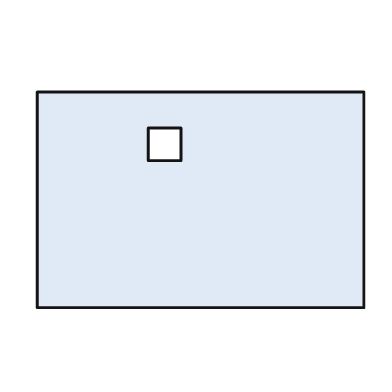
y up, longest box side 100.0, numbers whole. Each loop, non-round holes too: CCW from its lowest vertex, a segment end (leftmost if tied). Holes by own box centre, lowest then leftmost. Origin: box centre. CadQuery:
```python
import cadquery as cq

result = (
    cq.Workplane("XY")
    .moveTo(-50.0, -33.0)
    .lineTo(50.0, -33.0)
    .lineTo(50.0, 33.0)
    .lineTo(-50.0, 33.0)
    .close()
    .moveTo(-16.0, 12.0)
    .lineTo(-6.0, 12.0)
    .lineTo(-6.0, 22.0)
    .lineTo(-16.0, 22.0)
    .close()
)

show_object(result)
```